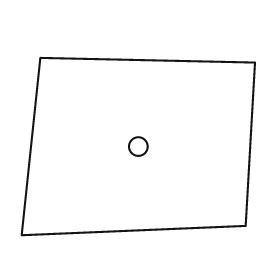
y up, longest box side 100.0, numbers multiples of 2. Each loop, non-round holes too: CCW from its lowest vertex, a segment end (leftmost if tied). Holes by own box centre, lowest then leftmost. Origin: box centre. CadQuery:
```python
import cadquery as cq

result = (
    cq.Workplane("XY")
    .moveTo(-50.0, -38.0)
    .lineTo(46.0, -34.0)
    .lineTo(50.0, 36.0)
    .lineTo(-42.0, 38.0)
    .close()
    .moveTo(0.0, 0.0)
    .circle(4.0)
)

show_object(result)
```